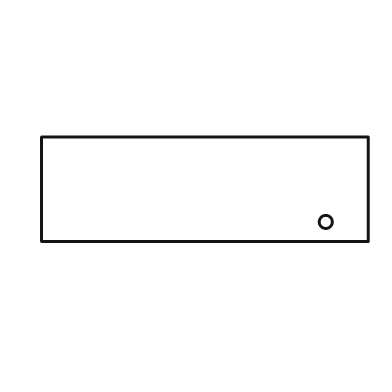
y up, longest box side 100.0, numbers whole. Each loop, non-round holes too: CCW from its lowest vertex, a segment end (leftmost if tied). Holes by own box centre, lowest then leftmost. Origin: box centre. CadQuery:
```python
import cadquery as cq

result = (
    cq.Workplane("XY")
    .moveTo(-50.0, -16.0)
    .lineTo(50.0, -16.0)
    .lineTo(50.0, 16.0)
    .lineTo(-50.0, 16.0)
    .close()
    .moveTo(37.0, -10.0)
    .circle(2.0)
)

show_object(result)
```